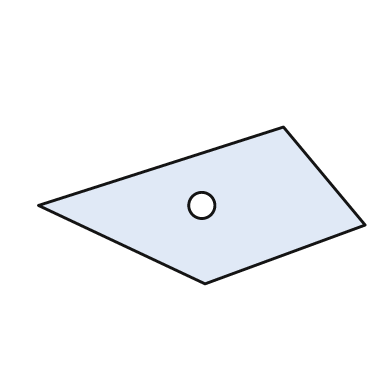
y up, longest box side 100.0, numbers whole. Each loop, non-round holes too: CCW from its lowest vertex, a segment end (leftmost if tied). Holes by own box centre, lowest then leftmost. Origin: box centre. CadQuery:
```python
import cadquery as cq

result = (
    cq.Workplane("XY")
    .moveTo(1.0, -24.0)
    .lineTo(50.0, -6.0)
    .lineTo(25.0, 24.0)
    .lineTo(-50.0, 0.0)
    .close()
    .moveTo(0.0, 0.0)
    .circle(4.0)
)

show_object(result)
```